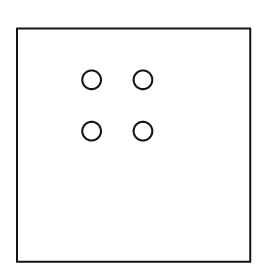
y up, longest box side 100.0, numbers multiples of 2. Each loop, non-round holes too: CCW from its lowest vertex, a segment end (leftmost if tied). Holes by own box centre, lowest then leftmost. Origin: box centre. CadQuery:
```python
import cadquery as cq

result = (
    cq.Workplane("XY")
    .moveTo(-50.0, -50.0)
    .lineTo(50.0, -50.0)
    .lineTo(50.0, 50.0)
    .lineTo(-50.0, 50.0)
    .close()
    .moveTo(-18.0, 6.0)
    .circle(4.0)
    .moveTo(4.0, 6.0)
    .circle(4.0)
    .moveTo(-18.0, 28.0)
    .circle(4.0)
    .moveTo(4.0, 28.0)
    .circle(4.0)
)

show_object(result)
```